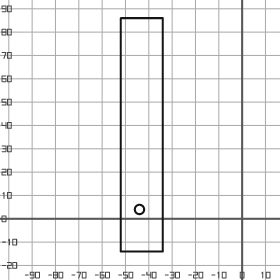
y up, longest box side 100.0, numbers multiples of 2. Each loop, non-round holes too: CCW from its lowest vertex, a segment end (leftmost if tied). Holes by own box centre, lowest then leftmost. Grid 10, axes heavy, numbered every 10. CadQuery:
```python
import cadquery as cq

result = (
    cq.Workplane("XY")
    .moveTo(-52.0, -14.0)
    .lineTo(-34.0, -14.0)
    .lineTo(-34.0, 86.0)
    .lineTo(-52.0, 86.0)
    .close()
    .moveTo(-44.0, 4.0)
    .circle(2.0)
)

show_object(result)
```